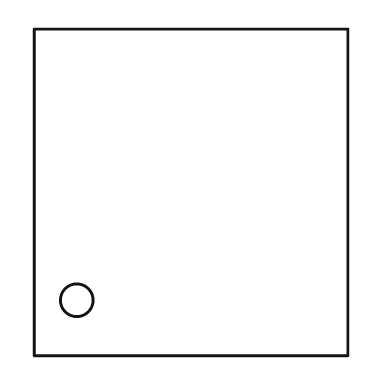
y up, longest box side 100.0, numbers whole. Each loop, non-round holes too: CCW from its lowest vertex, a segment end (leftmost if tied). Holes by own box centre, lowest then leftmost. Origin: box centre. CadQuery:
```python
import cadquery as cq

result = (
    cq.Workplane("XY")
    .moveTo(-48.0, -50.0)
    .lineTo(48.0, -50.0)
    .lineTo(48.0, 50.0)
    .lineTo(-48.0, 50.0)
    .close()
    .moveTo(-35.0, -33.0)
    .circle(5.0)
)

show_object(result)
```